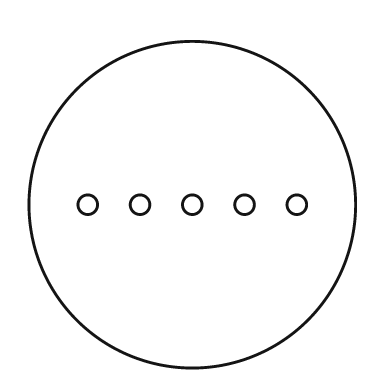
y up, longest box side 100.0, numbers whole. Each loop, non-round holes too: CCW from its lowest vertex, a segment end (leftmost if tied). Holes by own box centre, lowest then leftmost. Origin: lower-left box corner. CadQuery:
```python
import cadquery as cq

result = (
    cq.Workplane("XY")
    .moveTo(50.0, 50.0)
    .circle(50.0)
    .moveTo(18.0, 50.0)
    .circle(3.0)
    .moveTo(34.0, 50.0)
    .circle(3.0)
    .moveTo(50.0, 50.0)
    .circle(3.0)
    .moveTo(66.0, 50.0)
    .circle(3.0)
    .moveTo(82.0, 50.0)
    .circle(3.0)
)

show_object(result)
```